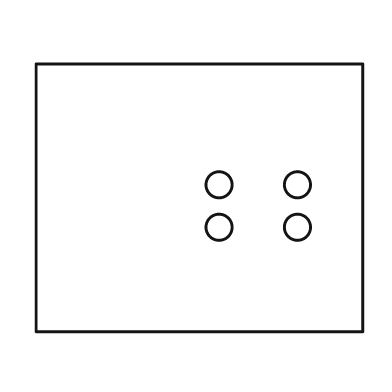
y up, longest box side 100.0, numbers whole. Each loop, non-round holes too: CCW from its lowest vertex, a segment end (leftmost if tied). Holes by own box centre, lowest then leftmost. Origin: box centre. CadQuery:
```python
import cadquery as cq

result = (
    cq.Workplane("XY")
    .moveTo(-50.0, -41.0)
    .lineTo(50.0, -41.0)
    .lineTo(50.0, 41.0)
    .lineTo(-50.0, 41.0)
    .close()
    .moveTo(6.0, -9.0)
    .circle(4.0)
    .moveTo(30.0, -9.0)
    .circle(4.0)
    .moveTo(6.0, 4.0)
    .circle(4.0)
    .moveTo(30.0, 4.0)
    .circle(4.0)
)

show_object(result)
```